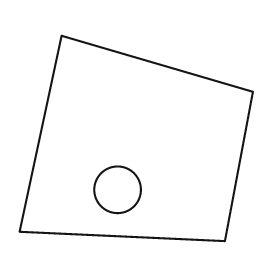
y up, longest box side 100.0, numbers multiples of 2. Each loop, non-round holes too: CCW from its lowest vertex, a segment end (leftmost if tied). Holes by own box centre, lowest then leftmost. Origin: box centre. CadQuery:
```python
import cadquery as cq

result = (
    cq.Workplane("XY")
    .moveTo(38.0, -44.0)
    .lineTo(50.0, 20.0)
    .lineTo(-32.0, 44.0)
    .lineTo(-50.0, -40.0)
    .close()
    .moveTo(-8.0, -22.0)
    .circle(10.0)
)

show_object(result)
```